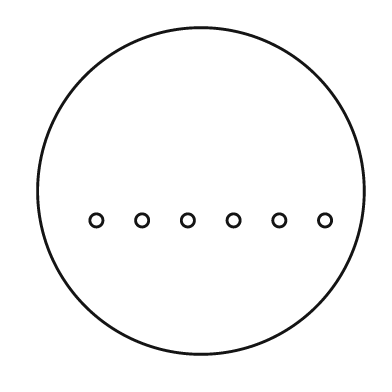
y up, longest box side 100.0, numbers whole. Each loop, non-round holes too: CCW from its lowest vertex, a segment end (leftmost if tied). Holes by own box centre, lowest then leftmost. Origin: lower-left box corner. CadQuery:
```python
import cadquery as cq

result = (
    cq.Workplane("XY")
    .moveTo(50.0, 50.0)
    .circle(50.0)
    .moveTo(18.0, 41.0)
    .circle(2.0)
    .moveTo(32.0, 41.0)
    .circle(2.0)
    .moveTo(46.0, 41.0)
    .circle(2.0)
    .moveTo(60.0, 41.0)
    .circle(2.0)
    .moveTo(74.0, 41.0)
    .circle(2.0)
    .moveTo(88.0, 41.0)
    .circle(2.0)
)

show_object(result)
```